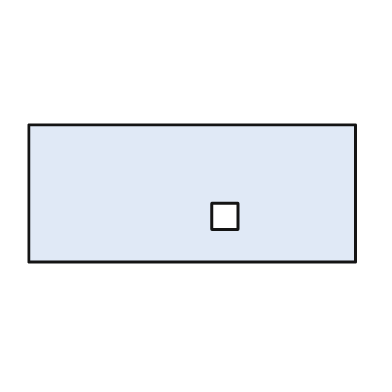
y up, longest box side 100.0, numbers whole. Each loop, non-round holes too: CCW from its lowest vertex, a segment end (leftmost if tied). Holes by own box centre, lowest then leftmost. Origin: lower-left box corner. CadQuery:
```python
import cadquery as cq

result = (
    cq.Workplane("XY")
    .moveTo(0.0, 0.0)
    .lineTo(100.0, 0.0)
    .lineTo(100.0, 42.0)
    .lineTo(0.0, 42.0)
    .close()
    .moveTo(56.0, 10.0)
    .lineTo(64.0, 10.0)
    .lineTo(64.0, 18.0)
    .lineTo(56.0, 18.0)
    .close()
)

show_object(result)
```